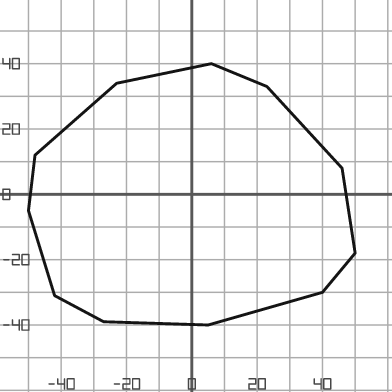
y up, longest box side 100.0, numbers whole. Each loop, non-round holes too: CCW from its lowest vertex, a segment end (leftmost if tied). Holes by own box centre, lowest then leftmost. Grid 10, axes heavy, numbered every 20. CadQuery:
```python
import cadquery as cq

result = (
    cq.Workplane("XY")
    .moveTo(5.0, -40.0)
    .lineTo(40.0, -30.0)
    .lineTo(50.0, -18.0)
    .lineTo(46.0, 8.0)
    .lineTo(23.0, 33.0)
    .lineTo(6.0, 40.0)
    .lineTo(-23.0, 34.0)
    .lineTo(-48.0, 12.0)
    .lineTo(-50.0, -5.0)
    .lineTo(-42.0, -31.0)
    .lineTo(-27.0, -39.0)
    .close()
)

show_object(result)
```